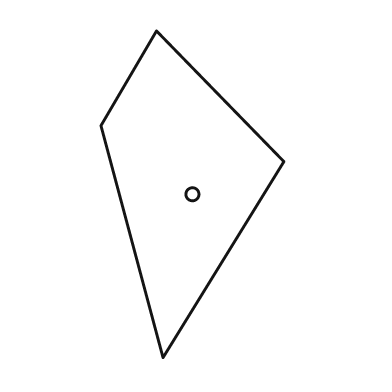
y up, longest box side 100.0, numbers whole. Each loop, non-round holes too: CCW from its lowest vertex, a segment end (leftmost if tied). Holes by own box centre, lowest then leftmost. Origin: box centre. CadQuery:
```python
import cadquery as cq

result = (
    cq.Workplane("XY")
    .moveTo(-9.0, -50.0)
    .lineTo(28.0, 10.0)
    .lineTo(-11.0, 50.0)
    .lineTo(-28.0, 21.0)
    .close()
    .moveTo(0.0, 0.0)
    .circle(2.0)
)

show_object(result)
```